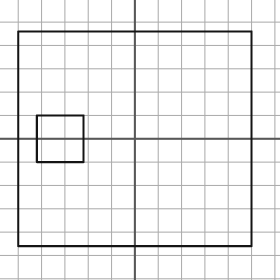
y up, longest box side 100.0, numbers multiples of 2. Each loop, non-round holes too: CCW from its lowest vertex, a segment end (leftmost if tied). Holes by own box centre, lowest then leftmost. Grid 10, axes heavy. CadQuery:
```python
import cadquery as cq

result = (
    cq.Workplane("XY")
    .moveTo(-50.0, -46.0)
    .lineTo(50.0, -46.0)
    .lineTo(50.0, 46.0)
    .lineTo(-50.0, 46.0)
    .close()
    .moveTo(-42.0, -10.0)
    .lineTo(-22.0, -10.0)
    .lineTo(-22.0, 10.0)
    .lineTo(-42.0, 10.0)
    .close()
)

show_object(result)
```